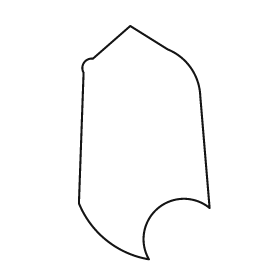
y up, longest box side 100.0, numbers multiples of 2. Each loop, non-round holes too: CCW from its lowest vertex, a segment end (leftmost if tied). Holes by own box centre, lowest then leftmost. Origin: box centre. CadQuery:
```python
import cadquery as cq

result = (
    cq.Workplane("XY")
    .moveTo(2.0, -50.0)
    .threePointArc((6.0, -28.0), (28.0, -28.0))
    .lineTo(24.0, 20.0)
    .threePointArc((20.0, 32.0), (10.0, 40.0))
    .lineTo(-6.0, 50.0)
    .lineTo(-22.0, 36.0)
    .threePointArc((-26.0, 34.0), (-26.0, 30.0))
    .lineTo(-28.0, -26.0)
    .threePointArc((-16.0, -42.0), (2.0, -50.0))
    .close()
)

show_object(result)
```